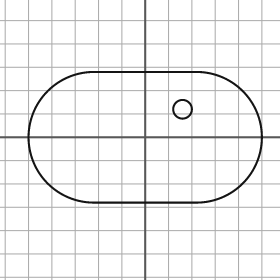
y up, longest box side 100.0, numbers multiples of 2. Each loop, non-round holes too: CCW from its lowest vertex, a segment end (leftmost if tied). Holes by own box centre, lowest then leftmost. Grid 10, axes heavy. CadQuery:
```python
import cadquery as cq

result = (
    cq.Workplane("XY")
    .moveTo(-22.0, -28.0)
    .lineTo(22.0, -28.0)
    .threePointArc((50.0, 0.0), (22.0, 28.0))
    .lineTo(-22.0, 28.0)
    .threePointArc((-50.0, 0.0), (-22.0, -28.0))
    .close()
    .moveTo(16.0, 12.0)
    .circle(4.0)
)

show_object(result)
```